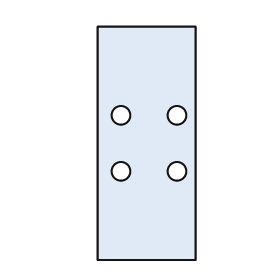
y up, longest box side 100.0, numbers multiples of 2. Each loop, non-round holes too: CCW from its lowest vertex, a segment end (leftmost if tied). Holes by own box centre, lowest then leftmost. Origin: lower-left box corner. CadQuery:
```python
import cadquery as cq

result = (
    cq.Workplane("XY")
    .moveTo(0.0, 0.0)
    .lineTo(42.0, 0.0)
    .lineTo(42.0, 100.0)
    .lineTo(0.0, 100.0)
    .close()
    .moveTo(10.0, 38.0)
    .circle(4.0)
    .moveTo(34.0, 38.0)
    .circle(4.0)
    .moveTo(10.0, 62.0)
    .circle(4.0)
    .moveTo(34.0, 62.0)
    .circle(4.0)
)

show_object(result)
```